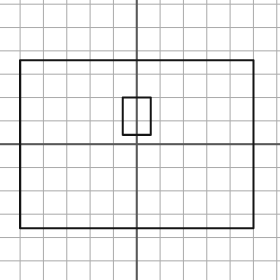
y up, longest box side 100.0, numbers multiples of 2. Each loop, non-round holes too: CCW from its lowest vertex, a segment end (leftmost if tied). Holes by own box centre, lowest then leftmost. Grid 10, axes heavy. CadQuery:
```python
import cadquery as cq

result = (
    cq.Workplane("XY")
    .moveTo(-50.0, -36.0)
    .lineTo(50.0, -36.0)
    .lineTo(50.0, 36.0)
    .lineTo(-50.0, 36.0)
    .close()
    .moveTo(-6.0, 4.0)
    .lineTo(6.0, 4.0)
    .lineTo(6.0, 20.0)
    .lineTo(-6.0, 20.0)
    .close()
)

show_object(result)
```